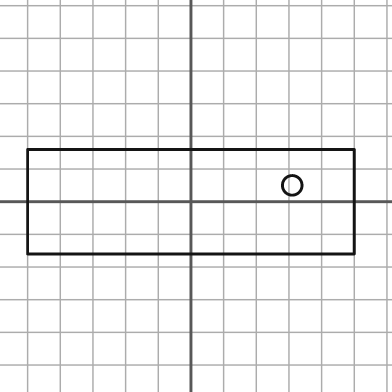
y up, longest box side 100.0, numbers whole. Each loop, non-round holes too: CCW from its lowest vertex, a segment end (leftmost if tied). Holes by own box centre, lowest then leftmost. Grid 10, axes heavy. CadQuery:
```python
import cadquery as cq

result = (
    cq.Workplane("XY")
    .moveTo(-50.0, -16.0)
    .lineTo(50.0, -16.0)
    .lineTo(50.0, 16.0)
    .lineTo(-50.0, 16.0)
    .close()
    .moveTo(31.0, 5.0)
    .circle(3.0)
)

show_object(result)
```